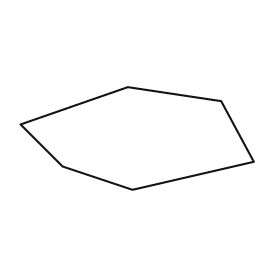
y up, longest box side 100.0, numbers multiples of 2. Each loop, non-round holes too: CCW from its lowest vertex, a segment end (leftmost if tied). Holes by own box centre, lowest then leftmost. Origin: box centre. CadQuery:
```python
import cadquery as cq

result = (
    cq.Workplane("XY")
    .moveTo(-2.0, -22.0)
    .lineTo(50.0, -10.0)
    .lineTo(36.0, 16.0)
    .lineTo(-4.0, 22.0)
    .lineTo(-50.0, 6.0)
    .lineTo(-32.0, -12.0)
    .close()
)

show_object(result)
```